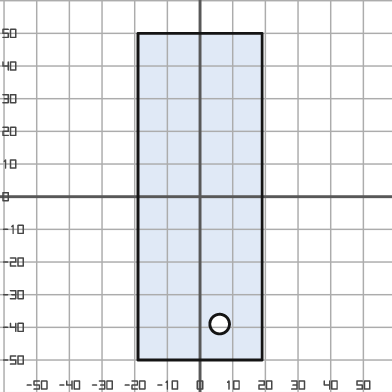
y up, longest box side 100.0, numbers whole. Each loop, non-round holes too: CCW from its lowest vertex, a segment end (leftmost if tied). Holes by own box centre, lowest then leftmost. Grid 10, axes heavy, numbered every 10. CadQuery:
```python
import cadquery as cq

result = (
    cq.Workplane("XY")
    .moveTo(-19.0, -50.0)
    .lineTo(19.0, -50.0)
    .lineTo(19.0, 50.0)
    .lineTo(-19.0, 50.0)
    .close()
    .moveTo(6.0, -39.0)
    .circle(3.0)
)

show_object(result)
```